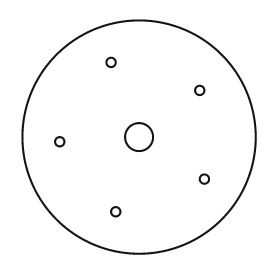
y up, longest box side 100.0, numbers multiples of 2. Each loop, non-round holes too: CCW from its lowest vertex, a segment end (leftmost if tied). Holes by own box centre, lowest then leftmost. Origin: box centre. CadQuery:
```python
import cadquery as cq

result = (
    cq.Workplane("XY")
    .moveTo(0.0, 0.0)
    .circle(50.0)
    .moveTo(-10.0, -32.0)
    .circle(2.0)
    .moveTo(28.0, -18.0)
    .circle(2.0)
    .moveTo(-34.0, -2.0)
    .circle(2.0)
    .moveTo(0.0, 0.0)
    .circle(6.0)
    .moveTo(26.0, 20.0)
    .circle(2.0)
    .moveTo(-12.0, 32.0)
    .circle(2.0)
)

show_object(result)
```